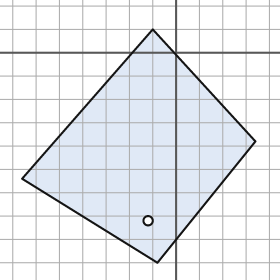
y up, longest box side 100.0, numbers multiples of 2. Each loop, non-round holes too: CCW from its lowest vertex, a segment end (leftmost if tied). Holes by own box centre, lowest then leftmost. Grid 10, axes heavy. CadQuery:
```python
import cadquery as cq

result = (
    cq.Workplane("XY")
    .moveTo(-8.0, -90.0)
    .lineTo(34.0, -38.0)
    .lineTo(-10.0, 10.0)
    .lineTo(-66.0, -54.0)
    .close()
    .moveTo(-12.0, -72.0)
    .circle(2.0)
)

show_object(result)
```